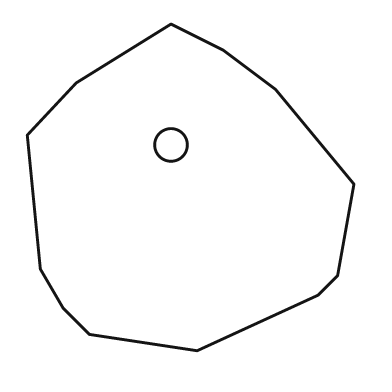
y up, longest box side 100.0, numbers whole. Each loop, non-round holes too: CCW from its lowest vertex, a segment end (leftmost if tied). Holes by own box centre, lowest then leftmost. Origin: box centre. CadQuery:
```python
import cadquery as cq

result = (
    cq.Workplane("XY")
    .moveTo(2.0, -50.0)
    .lineTo(39.0, -33.0)
    .lineTo(45.0, -27.0)
    .lineTo(50.0, 1.0)
    .lineTo(26.0, 30.0)
    .lineTo(10.0, 42.0)
    .lineTo(-6.0, 50.0)
    .lineTo(-35.0, 32.0)
    .lineTo(-50.0, 16.0)
    .lineTo(-46.0, -25.0)
    .lineTo(-39.0, -37.0)
    .lineTo(-31.0, -45.0)
    .close()
    .moveTo(-6.0, 13.0)
    .circle(5.0)
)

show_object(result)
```